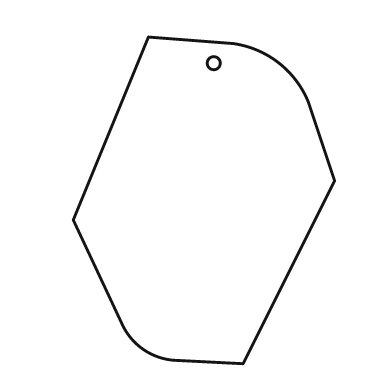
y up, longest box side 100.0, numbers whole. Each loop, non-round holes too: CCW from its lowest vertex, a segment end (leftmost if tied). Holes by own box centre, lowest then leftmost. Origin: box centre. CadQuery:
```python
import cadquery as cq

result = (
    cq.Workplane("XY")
    .moveTo(12.0, -50.0)
    .lineTo(40.0, 6.0)
    .lineTo(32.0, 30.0)
    .threePointArc((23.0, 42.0), (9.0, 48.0))
    .lineTo(-17.0, 50.0)
    .lineTo(-40.0, -6.0)
    .lineTo(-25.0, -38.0)
    .threePointArc((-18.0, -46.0), (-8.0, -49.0))
    .close()
    .moveTo(3.0, 42.0)
    .circle(2.0)
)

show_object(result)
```